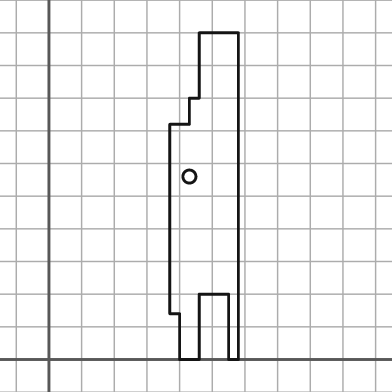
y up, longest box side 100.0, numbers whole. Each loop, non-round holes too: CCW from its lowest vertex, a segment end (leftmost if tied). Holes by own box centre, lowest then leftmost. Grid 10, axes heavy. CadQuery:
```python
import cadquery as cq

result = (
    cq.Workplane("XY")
    .moveTo(40.0, 0.0)
    .lineTo(46.0, 0.0)
    .lineTo(46.0, 20.0)
    .lineTo(55.0, 20.0)
    .lineTo(55.0, 0.0)
    .lineTo(58.0, 0.0)
    .lineTo(58.0, 100.0)
    .lineTo(46.0, 100.0)
    .lineTo(46.0, 80.0)
    .lineTo(43.0, 80.0)
    .lineTo(43.0, 72.0)
    .lineTo(37.0, 72.0)
    .lineTo(37.0, 14.0)
    .lineTo(40.0, 14.0)
    .close()
    .moveTo(43.0, 56.0)
    .circle(2.0)
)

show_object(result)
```